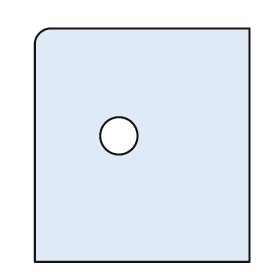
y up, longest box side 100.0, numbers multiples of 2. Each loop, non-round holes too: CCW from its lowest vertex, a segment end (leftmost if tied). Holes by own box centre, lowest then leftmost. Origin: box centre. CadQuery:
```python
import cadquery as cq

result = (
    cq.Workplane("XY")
    .moveTo(-46.0, -50.0)
    .lineTo(46.0, -50.0)
    .lineTo(46.0, 50.0)
    .lineTo(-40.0, 50.0)
    .threePointArc((-44.0, 48.0), (-46.0, 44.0))
    .close()
    .moveTo(-10.0, 4.0)
    .circle(8.0)
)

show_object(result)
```